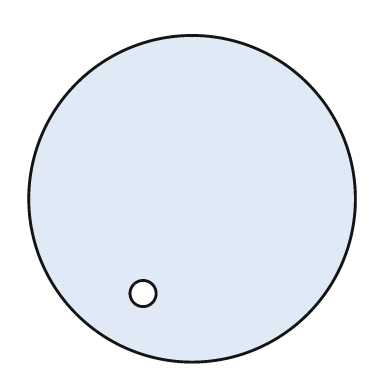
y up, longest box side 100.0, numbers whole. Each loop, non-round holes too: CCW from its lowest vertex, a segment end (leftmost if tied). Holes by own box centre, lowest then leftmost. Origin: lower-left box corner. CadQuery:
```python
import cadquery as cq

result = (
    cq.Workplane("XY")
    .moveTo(50.0, 50.0)
    .circle(50.0)
    .moveTo(35.0, 21.0)
    .circle(4.0)
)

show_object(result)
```